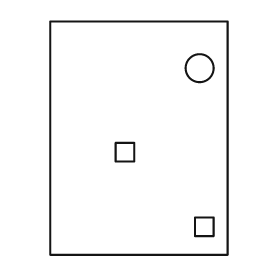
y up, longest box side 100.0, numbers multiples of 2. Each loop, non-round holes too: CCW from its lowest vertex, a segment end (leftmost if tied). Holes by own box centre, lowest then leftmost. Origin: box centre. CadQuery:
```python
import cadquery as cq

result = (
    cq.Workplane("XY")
    .moveTo(-38.0, -50.0)
    .lineTo(38.0, -50.0)
    .lineTo(38.0, 50.0)
    .lineTo(-38.0, 50.0)
    .close()
    .moveTo(24.0, -42.0)
    .lineTo(32.0, -42.0)
    .lineTo(32.0, -34.0)
    .lineTo(24.0, -34.0)
    .close()
    .moveTo(-10.0, -10.0)
    .lineTo(-2.0, -10.0)
    .lineTo(-2.0, -2.0)
    .lineTo(-10.0, -2.0)
    .close()
    .moveTo(26.0, 30.0)
    .circle(6.0)
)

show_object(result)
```